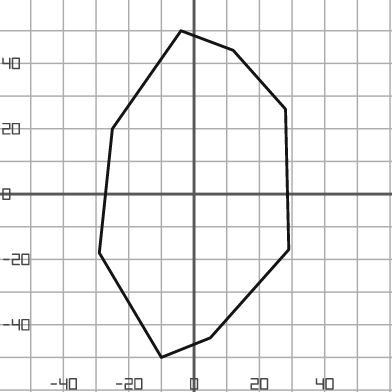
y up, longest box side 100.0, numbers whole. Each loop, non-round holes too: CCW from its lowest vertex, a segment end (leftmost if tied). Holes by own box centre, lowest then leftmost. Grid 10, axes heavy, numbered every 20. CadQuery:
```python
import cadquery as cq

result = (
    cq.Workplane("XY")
    .moveTo(-10.0, -50.0)
    .lineTo(5.0, -44.0)
    .lineTo(29.0, -17.0)
    .lineTo(28.0, 26.0)
    .lineTo(12.0, 44.0)
    .lineTo(-4.0, 50.0)
    .lineTo(-25.0, 20.0)
    .lineTo(-29.0, -18.0)
    .close()
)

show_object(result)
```